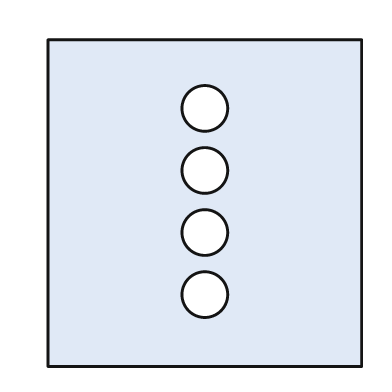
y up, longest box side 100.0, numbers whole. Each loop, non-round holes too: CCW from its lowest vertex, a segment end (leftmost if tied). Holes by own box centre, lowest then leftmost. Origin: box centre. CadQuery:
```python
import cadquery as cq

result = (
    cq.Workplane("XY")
    .moveTo(-48.0, -50.0)
    .lineTo(48.0, -50.0)
    .lineTo(48.0, 50.0)
    .lineTo(-48.0, 50.0)
    .close()
    .moveTo(0.0, -28.0)
    .circle(7.0)
    .moveTo(0.0, -9.0)
    .circle(7.0)
    .moveTo(0.0, 10.0)
    .circle(7.0)
    .moveTo(0.0, 29.0)
    .circle(7.0)
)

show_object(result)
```